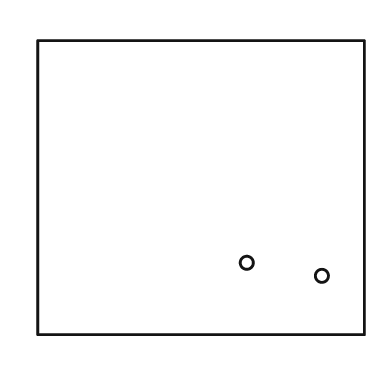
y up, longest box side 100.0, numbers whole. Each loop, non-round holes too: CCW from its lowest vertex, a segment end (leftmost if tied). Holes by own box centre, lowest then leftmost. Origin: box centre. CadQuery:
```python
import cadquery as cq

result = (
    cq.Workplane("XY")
    .moveTo(-50.0, -45.0)
    .lineTo(50.0, -45.0)
    .lineTo(50.0, 45.0)
    .lineTo(-50.0, 45.0)
    .close()
    .moveTo(37.0, -27.0)
    .circle(2.0)
    .moveTo(14.0, -23.0)
    .circle(2.0)
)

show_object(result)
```